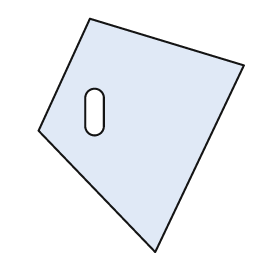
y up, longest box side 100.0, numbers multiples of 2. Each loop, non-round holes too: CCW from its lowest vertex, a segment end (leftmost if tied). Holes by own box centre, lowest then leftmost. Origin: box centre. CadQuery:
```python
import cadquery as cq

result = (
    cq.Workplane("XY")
    .moveTo(6.0, -50.0)
    .lineTo(44.0, 30.0)
    .lineTo(-22.0, 50.0)
    .lineTo(-44.0, 2.0)
    .close()
    .moveTo(-24.0, 4.0)
    .threePointArc((-20.0, 0.0), (-16.0, 4.0))
    .lineTo(-16.0, 16.0)
    .threePointArc((-20.0, 20.0), (-24.0, 16.0))
    .close()
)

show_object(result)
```